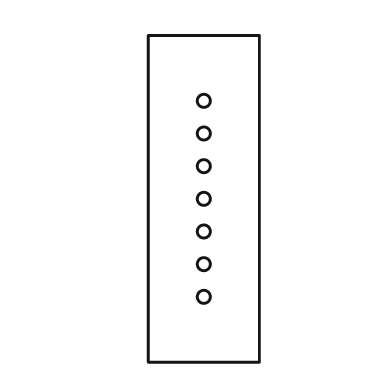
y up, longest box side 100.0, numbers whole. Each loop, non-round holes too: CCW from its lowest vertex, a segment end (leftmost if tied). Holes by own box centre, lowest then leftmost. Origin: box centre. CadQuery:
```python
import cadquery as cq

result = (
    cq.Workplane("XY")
    .moveTo(-17.0, -50.0)
    .lineTo(17.0, -50.0)
    .lineTo(17.0, 50.0)
    .lineTo(-17.0, 50.0)
    .close()
    .moveTo(0.0, -30.0)
    .circle(2.0)
    .moveTo(0.0, -20.0)
    .circle(2.0)
    .moveTo(0.0, -10.0)
    .circle(2.0)
    .moveTo(0.0, 0.0)
    .circle(2.0)
    .moveTo(0.0, 10.0)
    .circle(2.0)
    .moveTo(0.0, 20.0)
    .circle(2.0)
    .moveTo(0.0, 30.0)
    .circle(2.0)
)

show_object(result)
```